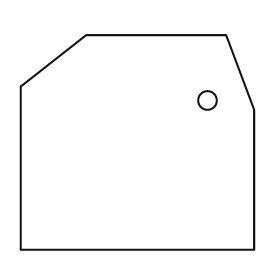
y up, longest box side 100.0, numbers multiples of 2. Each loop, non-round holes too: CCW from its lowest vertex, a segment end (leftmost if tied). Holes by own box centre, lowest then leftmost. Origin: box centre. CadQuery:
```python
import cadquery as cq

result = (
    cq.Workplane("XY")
    .moveTo(-50.0, -46.0)
    .lineTo(50.0, -46.0)
    .lineTo(50.0, 14.0)
    .lineTo(38.0, 46.0)
    .lineTo(-22.0, 46.0)
    .lineTo(-50.0, 24.0)
    .close()
    .moveTo(30.0, 18.0)
    .circle(4.0)
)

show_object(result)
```